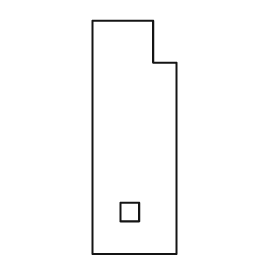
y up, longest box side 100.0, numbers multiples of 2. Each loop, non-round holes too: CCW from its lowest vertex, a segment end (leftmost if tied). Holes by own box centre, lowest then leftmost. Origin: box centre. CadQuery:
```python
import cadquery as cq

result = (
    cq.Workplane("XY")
    .moveTo(-18.0, -50.0)
    .lineTo(18.0, -50.0)
    .lineTo(18.0, 32.0)
    .lineTo(8.0, 32.0)
    .lineTo(8.0, 50.0)
    .lineTo(-18.0, 50.0)
    .close()
    .moveTo(-6.0, -36.0)
    .lineTo(2.0, -36.0)
    .lineTo(2.0, -28.0)
    .lineTo(-6.0, -28.0)
    .close()
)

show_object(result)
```